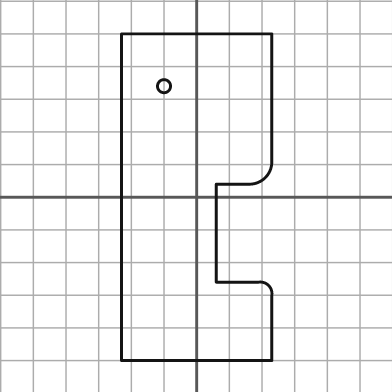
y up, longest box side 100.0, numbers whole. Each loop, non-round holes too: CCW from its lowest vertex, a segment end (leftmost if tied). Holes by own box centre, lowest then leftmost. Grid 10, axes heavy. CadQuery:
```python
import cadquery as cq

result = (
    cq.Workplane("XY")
    .moveTo(-23.0, -50.0)
    .lineTo(23.0, -50.0)
    .lineTo(23.0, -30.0)
    .threePointArc((22.0, -27.0), (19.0, -26.0))
    .lineTo(6.0, -26.0)
    .lineTo(6.0, 4.0)
    .lineTo(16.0, 4.0)
    .threePointArc((21.0, 6.0), (23.0, 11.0))
    .lineTo(23.0, 50.0)
    .lineTo(-23.0, 50.0)
    .close()
    .moveTo(-10.0, 34.0)
    .circle(2.0)
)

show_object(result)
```